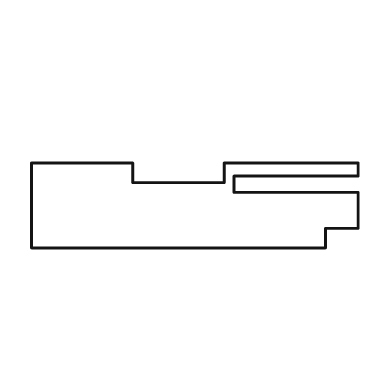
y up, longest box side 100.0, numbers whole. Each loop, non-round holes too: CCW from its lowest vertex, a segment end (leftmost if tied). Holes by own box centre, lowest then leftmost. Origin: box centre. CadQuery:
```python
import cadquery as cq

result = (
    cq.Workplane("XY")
    .moveTo(-50.0, -13.0)
    .lineTo(40.0, -13.0)
    .lineTo(40.0, -7.0)
    .lineTo(50.0, -7.0)
    .lineTo(50.0, 4.0)
    .lineTo(12.0, 4.0)
    .lineTo(12.0, 9.0)
    .lineTo(50.0, 9.0)
    .lineTo(50.0, 13.0)
    .lineTo(9.0, 13.0)
    .lineTo(9.0, 7.0)
    .lineTo(-19.0, 7.0)
    .lineTo(-19.0, 13.0)
    .lineTo(-50.0, 13.0)
    .close()
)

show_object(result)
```